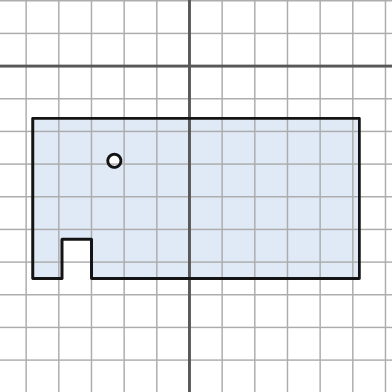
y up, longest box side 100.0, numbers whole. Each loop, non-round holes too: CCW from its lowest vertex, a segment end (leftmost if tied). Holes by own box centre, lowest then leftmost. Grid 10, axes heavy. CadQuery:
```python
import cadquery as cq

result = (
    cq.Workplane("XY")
    .moveTo(-48.0, -65.0)
    .lineTo(-39.0, -65.0)
    .lineTo(-39.0, -53.0)
    .lineTo(-30.0, -53.0)
    .lineTo(-30.0, -65.0)
    .lineTo(52.0, -65.0)
    .lineTo(52.0, -16.0)
    .lineTo(-48.0, -16.0)
    .close()
    .moveTo(-23.0, -29.0)
    .circle(2.0)
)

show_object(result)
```